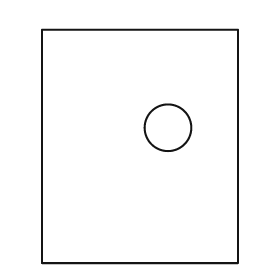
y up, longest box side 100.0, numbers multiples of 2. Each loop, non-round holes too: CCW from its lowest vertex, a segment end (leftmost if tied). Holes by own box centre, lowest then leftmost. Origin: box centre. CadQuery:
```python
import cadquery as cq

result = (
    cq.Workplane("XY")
    .moveTo(-42.0, -50.0)
    .lineTo(42.0, -50.0)
    .lineTo(42.0, 50.0)
    .lineTo(-42.0, 50.0)
    .close()
    .moveTo(12.0, 8.0)
    .circle(10.0)
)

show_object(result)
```